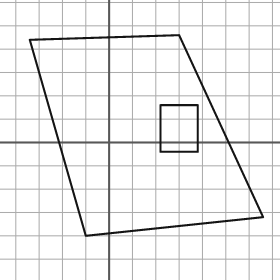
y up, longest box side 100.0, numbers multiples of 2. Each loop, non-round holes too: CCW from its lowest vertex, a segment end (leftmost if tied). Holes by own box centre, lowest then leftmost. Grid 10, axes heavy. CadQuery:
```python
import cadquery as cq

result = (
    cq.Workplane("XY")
    .moveTo(-10.0, -40.0)
    .lineTo(66.0, -32.0)
    .lineTo(30.0, 46.0)
    .lineTo(-34.0, 44.0)
    .close()
    .moveTo(22.0, -4.0)
    .lineTo(38.0, -4.0)
    .lineTo(38.0, 16.0)
    .lineTo(22.0, 16.0)
    .close()
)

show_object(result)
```